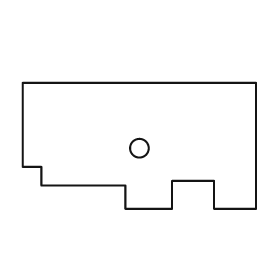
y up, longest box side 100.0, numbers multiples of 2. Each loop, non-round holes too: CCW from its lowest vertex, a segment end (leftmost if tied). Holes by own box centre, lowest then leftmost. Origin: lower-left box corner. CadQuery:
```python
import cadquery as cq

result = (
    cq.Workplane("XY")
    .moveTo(44.0, 0.0)
    .lineTo(64.0, 0.0)
    .lineTo(64.0, 12.0)
    .lineTo(82.0, 12.0)
    .lineTo(82.0, 0.0)
    .lineTo(100.0, 0.0)
    .lineTo(100.0, 54.0)
    .lineTo(0.0, 54.0)
    .lineTo(0.0, 18.0)
    .lineTo(8.0, 18.0)
    .lineTo(8.0, 10.0)
    .lineTo(44.0, 10.0)
    .close()
    .moveTo(50.0, 26.0)
    .circle(4.0)
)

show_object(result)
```